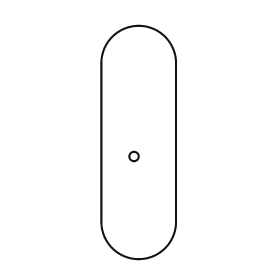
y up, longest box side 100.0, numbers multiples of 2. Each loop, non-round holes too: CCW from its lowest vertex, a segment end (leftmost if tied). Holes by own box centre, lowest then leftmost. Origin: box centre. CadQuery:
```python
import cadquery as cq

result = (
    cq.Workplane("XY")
    .moveTo(-16.0, -34.0)
    .threePointArc((0.0, -50.0), (16.0, -34.0))
    .lineTo(16.0, 34.0)
    .threePointArc((0.0, 50.0), (-16.0, 34.0))
    .close()
    .moveTo(-2.0, -6.0)
    .circle(2.0)
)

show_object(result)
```